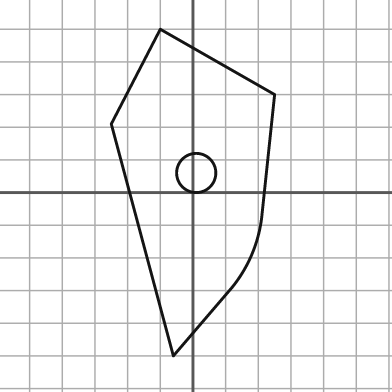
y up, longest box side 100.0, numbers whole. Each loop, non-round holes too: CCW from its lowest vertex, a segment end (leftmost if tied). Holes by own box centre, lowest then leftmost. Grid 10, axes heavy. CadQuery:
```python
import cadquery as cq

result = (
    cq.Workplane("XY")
    .moveTo(-6.0, -50.0)
    .lineTo(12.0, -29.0)
    .threePointArc((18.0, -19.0), (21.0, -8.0))
    .lineTo(25.0, 30.0)
    .lineTo(-10.0, 50.0)
    .lineTo(-25.0, 21.0)
    .close()
    .moveTo(1.0, 6.0)
    .circle(6.0)
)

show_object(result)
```